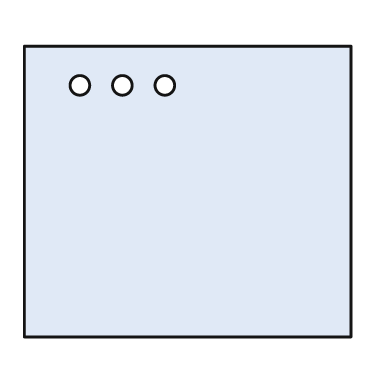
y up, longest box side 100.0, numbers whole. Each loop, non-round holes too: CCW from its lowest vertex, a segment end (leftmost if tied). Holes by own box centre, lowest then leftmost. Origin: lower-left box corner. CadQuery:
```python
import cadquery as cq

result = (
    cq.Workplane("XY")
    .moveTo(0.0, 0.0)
    .lineTo(100.0, 0.0)
    .lineTo(100.0, 89.0)
    .lineTo(0.0, 89.0)
    .close()
    .moveTo(17.0, 77.0)
    .circle(3.0)
    .moveTo(30.0, 77.0)
    .circle(3.0)
    .moveTo(43.0, 77.0)
    .circle(3.0)
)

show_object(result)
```